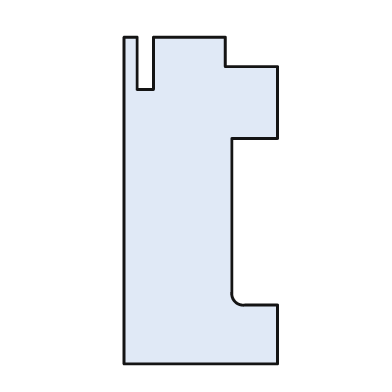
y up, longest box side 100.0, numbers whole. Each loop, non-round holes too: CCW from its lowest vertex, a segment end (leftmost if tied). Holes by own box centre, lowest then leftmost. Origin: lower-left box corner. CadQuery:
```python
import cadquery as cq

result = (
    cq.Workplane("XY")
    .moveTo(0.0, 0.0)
    .lineTo(47.0, 0.0)
    .lineTo(47.0, 18.0)
    .lineTo(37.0, 18.0)
    .threePointArc((34.0, 19.0), (33.0, 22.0))
    .lineTo(33.0, 69.0)
    .lineTo(47.0, 69.0)
    .lineTo(47.0, 91.0)
    .lineTo(31.0, 91.0)
    .lineTo(31.0, 100.0)
    .lineTo(9.0, 100.0)
    .lineTo(9.0, 84.0)
    .lineTo(4.0, 84.0)
    .lineTo(4.0, 100.0)
    .lineTo(0.0, 100.0)
    .close()
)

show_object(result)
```